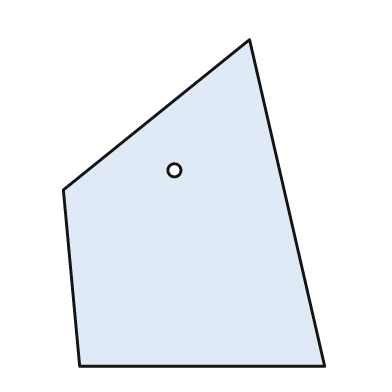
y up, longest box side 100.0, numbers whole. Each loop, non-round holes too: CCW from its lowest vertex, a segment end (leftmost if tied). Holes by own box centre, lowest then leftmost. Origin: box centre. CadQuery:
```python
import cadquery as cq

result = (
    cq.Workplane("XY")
    .moveTo(-35.0, -50.0)
    .lineTo(40.0, -50.0)
    .lineTo(17.0, 50.0)
    .lineTo(-40.0, 4.0)
    .close()
    .moveTo(-6.0, 10.0)
    .circle(2.0)
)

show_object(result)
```